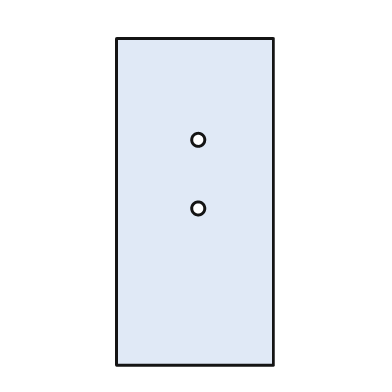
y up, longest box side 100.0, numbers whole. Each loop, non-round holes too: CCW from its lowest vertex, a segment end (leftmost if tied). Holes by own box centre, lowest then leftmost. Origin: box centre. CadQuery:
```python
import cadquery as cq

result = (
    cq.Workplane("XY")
    .moveTo(-24.0, -50.0)
    .lineTo(24.0, -50.0)
    .lineTo(24.0, 50.0)
    .lineTo(-24.0, 50.0)
    .close()
    .moveTo(1.0, -2.0)
    .circle(2.0)
    .moveTo(1.0, 19.0)
    .circle(2.0)
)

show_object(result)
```